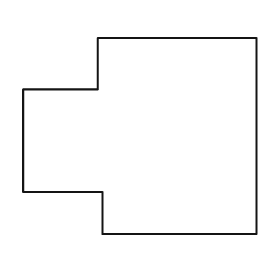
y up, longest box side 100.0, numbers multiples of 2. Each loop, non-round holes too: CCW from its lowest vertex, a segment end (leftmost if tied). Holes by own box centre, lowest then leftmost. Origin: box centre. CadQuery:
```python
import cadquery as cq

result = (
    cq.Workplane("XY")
    .moveTo(-16.0, -42.0)
    .lineTo(50.0, -42.0)
    .lineTo(50.0, 42.0)
    .lineTo(-18.0, 42.0)
    .lineTo(-18.0, 20.0)
    .lineTo(-50.0, 20.0)
    .lineTo(-50.0, -24.0)
    .lineTo(-16.0, -24.0)
    .close()
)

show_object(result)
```